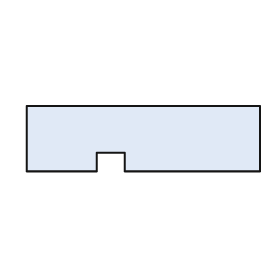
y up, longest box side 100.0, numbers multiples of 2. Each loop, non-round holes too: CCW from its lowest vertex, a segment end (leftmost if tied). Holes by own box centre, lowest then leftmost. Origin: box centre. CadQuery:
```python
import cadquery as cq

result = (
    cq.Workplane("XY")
    .moveTo(-50.0, -14.0)
    .lineTo(-20.0, -14.0)
    .lineTo(-20.0, -6.0)
    .lineTo(-8.0, -6.0)
    .lineTo(-8.0, -14.0)
    .lineTo(50.0, -14.0)
    .lineTo(50.0, 14.0)
    .lineTo(-50.0, 14.0)
    .close()
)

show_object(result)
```